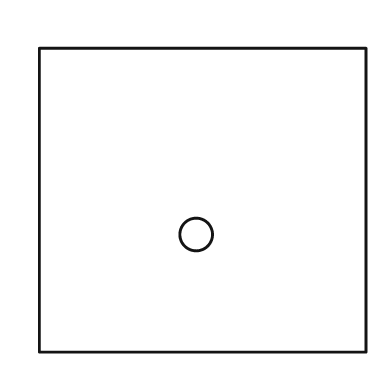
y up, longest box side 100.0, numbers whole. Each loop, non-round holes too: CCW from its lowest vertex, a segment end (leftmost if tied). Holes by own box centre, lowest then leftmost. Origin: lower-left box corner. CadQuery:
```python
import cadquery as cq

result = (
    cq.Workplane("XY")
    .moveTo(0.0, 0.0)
    .lineTo(100.0, 0.0)
    .lineTo(100.0, 93.0)
    .lineTo(0.0, 93.0)
    .close()
    .moveTo(48.0, 36.0)
    .circle(5.0)
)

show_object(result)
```